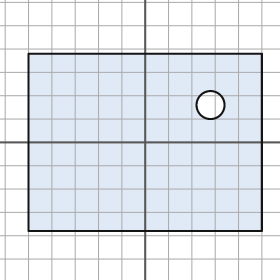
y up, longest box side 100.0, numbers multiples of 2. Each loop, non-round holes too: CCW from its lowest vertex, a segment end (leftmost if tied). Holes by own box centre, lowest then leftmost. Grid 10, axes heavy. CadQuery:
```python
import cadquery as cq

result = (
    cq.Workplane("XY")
    .moveTo(-50.0, -38.0)
    .lineTo(50.0, -38.0)
    .lineTo(50.0, 38.0)
    .lineTo(-50.0, 38.0)
    .close()
    .moveTo(28.0, 16.0)
    .circle(6.0)
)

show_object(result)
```